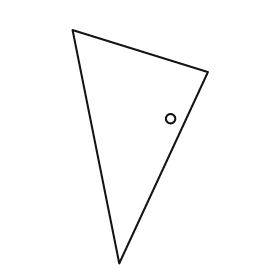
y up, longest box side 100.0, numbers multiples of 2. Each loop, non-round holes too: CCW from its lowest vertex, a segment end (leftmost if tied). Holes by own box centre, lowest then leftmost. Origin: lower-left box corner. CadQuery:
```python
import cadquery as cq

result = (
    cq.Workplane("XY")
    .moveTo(20.0, 0.0)
    .lineTo(58.0, 82.0)
    .lineTo(0.0, 100.0)
    .close()
    .moveTo(42.0, 62.0)
    .circle(2.0)
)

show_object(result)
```